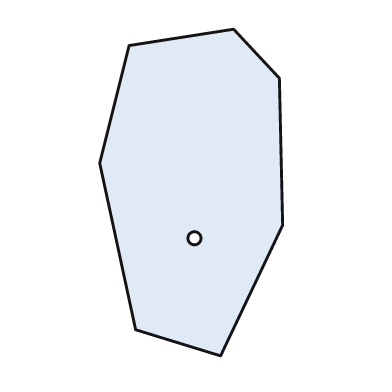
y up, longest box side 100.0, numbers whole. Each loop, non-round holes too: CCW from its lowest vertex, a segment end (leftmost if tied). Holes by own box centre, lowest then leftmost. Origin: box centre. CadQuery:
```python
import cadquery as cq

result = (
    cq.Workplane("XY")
    .moveTo(9.0, -50.0)
    .lineTo(28.0, -10.0)
    .lineTo(27.0, 35.0)
    .lineTo(13.0, 50.0)
    .lineTo(-19.0, 45.0)
    .lineTo(-28.0, 9.0)
    .lineTo(-17.0, -42.0)
    .close()
    .moveTo(1.0, -14.0)
    .circle(2.0)
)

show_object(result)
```